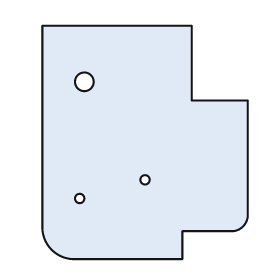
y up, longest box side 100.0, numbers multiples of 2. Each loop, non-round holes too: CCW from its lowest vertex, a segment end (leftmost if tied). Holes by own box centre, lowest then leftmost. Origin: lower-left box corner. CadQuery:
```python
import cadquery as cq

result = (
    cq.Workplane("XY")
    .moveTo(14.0, 0.0)
    .lineTo(60.0, 0.0)
    .lineTo(60.0, 12.0)
    .lineTo(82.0, 12.0)
    .threePointArc((86.0, 14.0), (88.0, 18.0))
    .lineTo(88.0, 68.0)
    .lineTo(64.0, 68.0)
    .lineTo(64.0, 100.0)
    .lineTo(0.0, 100.0)
    .lineTo(0.0, 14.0)
    .threePointArc((4.0, 4.0), (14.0, 0.0))
    .close()
    .moveTo(16.0, 26.0)
    .circle(2.0)
    .moveTo(44.0, 34.0)
    .circle(2.0)
    .moveTo(18.0, 76.0)
    .circle(4.0)
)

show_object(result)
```